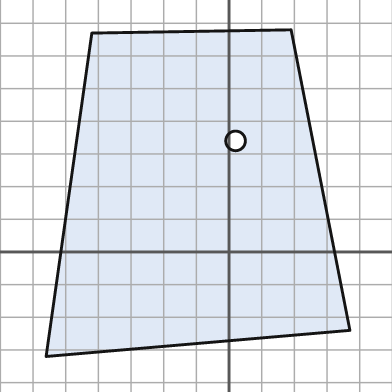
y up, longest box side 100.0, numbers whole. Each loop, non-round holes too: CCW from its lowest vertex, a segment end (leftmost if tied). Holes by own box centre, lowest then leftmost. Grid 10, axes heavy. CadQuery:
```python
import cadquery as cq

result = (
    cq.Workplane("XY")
    .moveTo(-56.0, -32.0)
    .lineTo(37.0, -24.0)
    .lineTo(19.0, 68.0)
    .lineTo(-42.0, 67.0)
    .close()
    .moveTo(2.0, 34.0)
    .circle(3.0)
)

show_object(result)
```